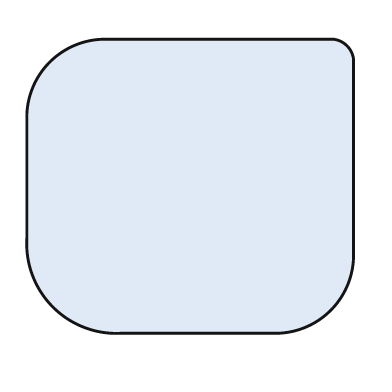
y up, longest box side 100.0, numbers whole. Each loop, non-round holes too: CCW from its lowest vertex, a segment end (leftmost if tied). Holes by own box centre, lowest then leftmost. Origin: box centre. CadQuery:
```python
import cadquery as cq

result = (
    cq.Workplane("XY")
    .moveTo(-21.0, -45.0)
    .lineTo(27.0, -45.0)
    .threePointArc((43.0, -38.0), (50.0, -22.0))
    .lineTo(50.0, 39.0)
    .threePointArc((48.0, 43.0), (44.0, 45.0))
    .lineTo(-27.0, 45.0)
    .threePointArc((-43.0, 38.0), (-50.0, 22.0))
    .lineTo(-50.0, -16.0)
    .threePointArc((-42.0, -37.0), (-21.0, -45.0))
    .close()
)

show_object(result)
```